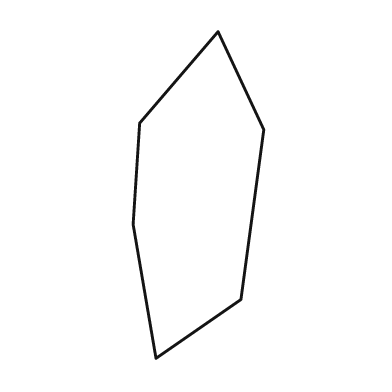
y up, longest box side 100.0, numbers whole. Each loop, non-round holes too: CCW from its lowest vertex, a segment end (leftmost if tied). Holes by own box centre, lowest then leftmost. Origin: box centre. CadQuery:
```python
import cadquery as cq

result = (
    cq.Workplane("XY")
    .moveTo(-13.0, -50.0)
    .lineTo(13.0, -32.0)
    .lineTo(20.0, 20.0)
    .lineTo(6.0, 50.0)
    .lineTo(-18.0, 22.0)
    .lineTo(-20.0, -9.0)
    .close()
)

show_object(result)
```